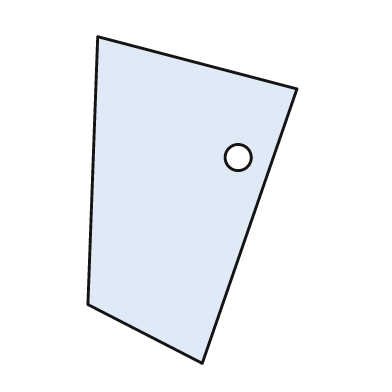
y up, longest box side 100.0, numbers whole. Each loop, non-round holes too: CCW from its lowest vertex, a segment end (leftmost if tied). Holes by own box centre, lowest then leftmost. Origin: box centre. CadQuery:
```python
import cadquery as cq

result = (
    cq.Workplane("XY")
    .moveTo(3.0, -50.0)
    .lineTo(32.0, 34.0)
    .lineTo(-29.0, 50.0)
    .lineTo(-32.0, -32.0)
    .close()
    .moveTo(14.0, 13.0)
    .circle(4.0)
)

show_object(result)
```